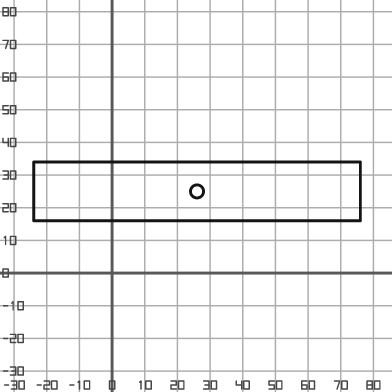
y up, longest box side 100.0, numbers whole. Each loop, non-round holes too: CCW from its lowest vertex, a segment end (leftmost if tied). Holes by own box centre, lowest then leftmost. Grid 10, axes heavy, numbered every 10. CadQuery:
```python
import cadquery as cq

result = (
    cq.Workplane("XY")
    .moveTo(-24.0, 16.0)
    .lineTo(76.0, 16.0)
    .lineTo(76.0, 34.0)
    .lineTo(-24.0, 34.0)
    .close()
    .moveTo(26.0, 25.0)
    .circle(2.0)
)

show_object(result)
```